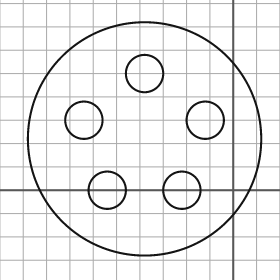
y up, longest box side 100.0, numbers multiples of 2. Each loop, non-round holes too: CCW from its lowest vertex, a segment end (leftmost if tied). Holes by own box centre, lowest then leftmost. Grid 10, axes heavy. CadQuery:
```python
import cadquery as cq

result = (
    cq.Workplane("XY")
    .moveTo(-38.0, 22.0)
    .circle(50.0)
    .moveTo(-54.0, 0.0)
    .circle(8.0)
    .moveTo(-22.0, 0.0)
    .circle(8.0)
    .moveTo(-64.0, 30.0)
    .circle(8.0)
    .moveTo(-12.0, 30.0)
    .circle(8.0)
    .moveTo(-38.0, 50.0)
    .circle(8.0)
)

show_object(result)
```